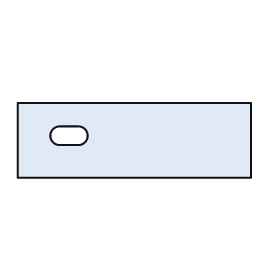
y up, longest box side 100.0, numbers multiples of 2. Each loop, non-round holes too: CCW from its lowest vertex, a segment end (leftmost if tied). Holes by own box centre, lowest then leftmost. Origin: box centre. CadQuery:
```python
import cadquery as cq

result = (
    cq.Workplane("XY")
    .moveTo(-50.0, -16.0)
    .lineTo(50.0, -16.0)
    .lineTo(50.0, 16.0)
    .lineTo(-50.0, 16.0)
    .close()
    .moveTo(-32.0, -2.0)
    .lineTo(-24.0, -2.0)
    .threePointArc((-20.0, 2.0), (-24.0, 6.0))
    .lineTo(-32.0, 6.0)
    .threePointArc((-36.0, 2.0), (-32.0, -2.0))
    .close()
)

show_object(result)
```